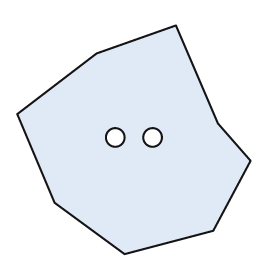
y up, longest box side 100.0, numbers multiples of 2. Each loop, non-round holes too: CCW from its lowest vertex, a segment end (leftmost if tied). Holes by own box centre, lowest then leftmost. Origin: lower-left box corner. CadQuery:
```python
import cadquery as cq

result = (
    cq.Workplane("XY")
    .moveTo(46.0, 0.0)
    .lineTo(84.0, 10.0)
    .lineTo(100.0, 40.0)
    .lineTo(86.0, 56.0)
    .lineTo(68.0, 98.0)
    .lineTo(34.0, 86.0)
    .lineTo(0.0, 60.0)
    .lineTo(16.0, 22.0)
    .close()
    .moveTo(42.0, 50.0)
    .circle(4.0)
    .moveTo(58.0, 50.0)
    .circle(4.0)
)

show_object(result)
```